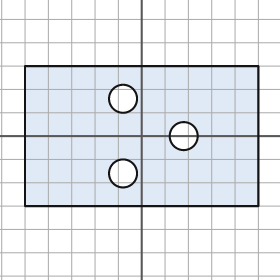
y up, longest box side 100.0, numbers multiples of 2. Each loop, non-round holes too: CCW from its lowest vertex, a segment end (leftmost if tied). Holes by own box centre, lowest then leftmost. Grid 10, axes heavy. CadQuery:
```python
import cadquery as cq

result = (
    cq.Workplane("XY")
    .moveTo(-50.0, -30.0)
    .lineTo(50.0, -30.0)
    .lineTo(50.0, 30.0)
    .lineTo(-50.0, 30.0)
    .close()
    .moveTo(-8.0, -16.0)
    .circle(6.0)
    .moveTo(18.0, 0.0)
    .circle(6.0)
    .moveTo(-8.0, 16.0)
    .circle(6.0)
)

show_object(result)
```